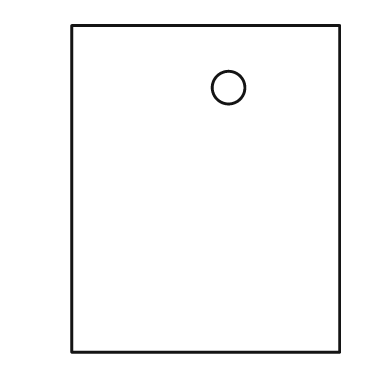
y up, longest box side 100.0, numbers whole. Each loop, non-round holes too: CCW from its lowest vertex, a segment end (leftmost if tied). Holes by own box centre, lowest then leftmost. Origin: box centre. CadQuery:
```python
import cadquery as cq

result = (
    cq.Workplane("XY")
    .moveTo(-41.0, -50.0)
    .lineTo(41.0, -50.0)
    .lineTo(41.0, 50.0)
    .lineTo(-41.0, 50.0)
    .close()
    .moveTo(7.0, 31.0)
    .circle(5.0)
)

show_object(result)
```